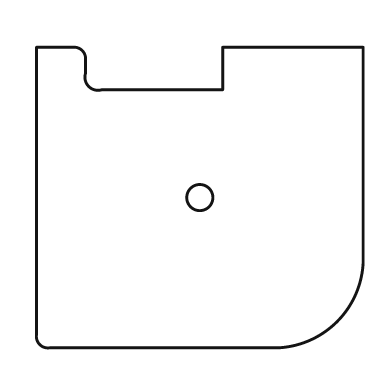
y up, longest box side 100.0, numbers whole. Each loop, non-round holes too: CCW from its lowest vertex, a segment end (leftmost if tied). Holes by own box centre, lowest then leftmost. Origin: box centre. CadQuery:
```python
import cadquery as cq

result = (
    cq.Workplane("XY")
    .moveTo(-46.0, -46.0)
    .lineTo(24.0, -46.0)
    .threePointArc((42.0, -38.0), (50.0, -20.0))
    .lineTo(50.0, 46.0)
    .lineTo(7.0, 46.0)
    .lineTo(7.0, 33.0)
    .lineTo(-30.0, 33.0)
    .threePointArc((-34.0, 34.0), (-35.0, 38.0))
    .lineTo(-35.0, 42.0)
    .threePointArc((-36.0, 45.0), (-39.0, 46.0))
    .lineTo(-50.0, 46.0)
    .lineTo(-50.0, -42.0)
    .threePointArc((-49.0, -45.0), (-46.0, -46.0))
    .close()
    .moveTo(0.0, 0.0)
    .circle(4.0)
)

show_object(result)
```